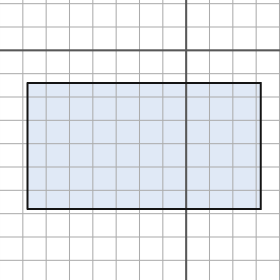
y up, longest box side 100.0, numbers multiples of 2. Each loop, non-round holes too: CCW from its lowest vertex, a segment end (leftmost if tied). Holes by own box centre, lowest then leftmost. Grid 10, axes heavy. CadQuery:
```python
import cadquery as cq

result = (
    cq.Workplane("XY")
    .moveTo(-68.0, -68.0)
    .lineTo(32.0, -68.0)
    .lineTo(32.0, -14.0)
    .lineTo(-68.0, -14.0)
    .close()
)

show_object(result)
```